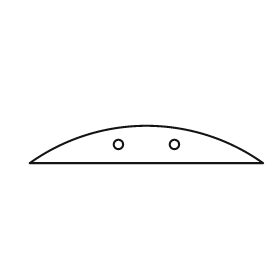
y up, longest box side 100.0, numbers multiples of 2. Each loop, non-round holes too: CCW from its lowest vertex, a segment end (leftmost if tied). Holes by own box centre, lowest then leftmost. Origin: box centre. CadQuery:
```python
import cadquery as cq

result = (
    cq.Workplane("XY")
    .moveTo(-50.0, -8.0)
    .lineTo(50.0, -8.0)
    .threePointArc((0.0, 8.0), (-50.0, -8.0))
    .close()
    .moveTo(-12.0, 0.0)
    .circle(2.0)
    .moveTo(12.0, 0.0)
    .circle(2.0)
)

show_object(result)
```